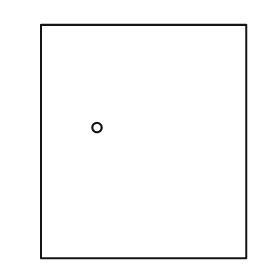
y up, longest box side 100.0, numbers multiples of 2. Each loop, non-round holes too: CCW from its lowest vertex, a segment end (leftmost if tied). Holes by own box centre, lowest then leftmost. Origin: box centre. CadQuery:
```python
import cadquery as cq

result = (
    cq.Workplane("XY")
    .moveTo(-44.0, -50.0)
    .lineTo(44.0, -50.0)
    .lineTo(44.0, 50.0)
    .lineTo(-44.0, 50.0)
    .close()
    .moveTo(-20.0, 6.0)
    .circle(2.0)
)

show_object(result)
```